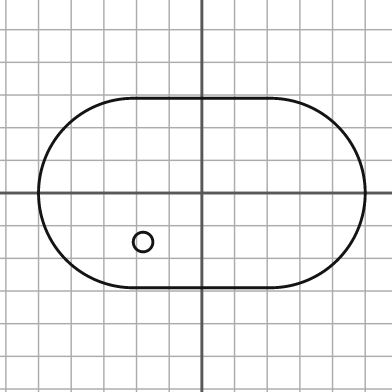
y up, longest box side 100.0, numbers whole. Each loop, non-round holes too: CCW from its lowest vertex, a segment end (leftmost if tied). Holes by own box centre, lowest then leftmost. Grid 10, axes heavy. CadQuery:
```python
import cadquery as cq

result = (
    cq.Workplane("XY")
    .moveTo(-21.0, -29.0)
    .lineTo(21.0, -29.0)
    .threePointArc((50.0, 0.0), (21.0, 29.0))
    .lineTo(-21.0, 29.0)
    .threePointArc((-50.0, 0.0), (-21.0, -29.0))
    .close()
    .moveTo(-18.0, -15.0)
    .circle(3.0)
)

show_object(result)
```